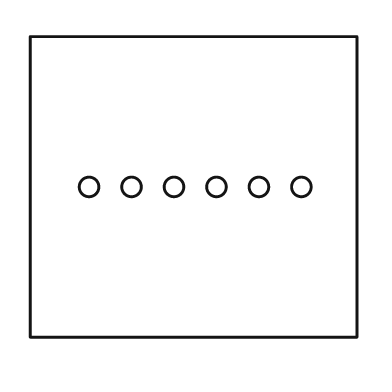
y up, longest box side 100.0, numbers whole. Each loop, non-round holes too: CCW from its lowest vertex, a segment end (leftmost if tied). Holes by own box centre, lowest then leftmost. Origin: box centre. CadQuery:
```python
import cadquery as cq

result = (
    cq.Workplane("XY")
    .moveTo(-50.0, -46.0)
    .lineTo(50.0, -46.0)
    .lineTo(50.0, 46.0)
    .lineTo(-50.0, 46.0)
    .close()
    .moveTo(-32.0, 0.0)
    .circle(3.0)
    .moveTo(-19.0, 0.0)
    .circle(3.0)
    .moveTo(-6.0, 0.0)
    .circle(3.0)
    .moveTo(7.0, 0.0)
    .circle(3.0)
    .moveTo(20.0, 0.0)
    .circle(3.0)
    .moveTo(33.0, 0.0)
    .circle(3.0)
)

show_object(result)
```